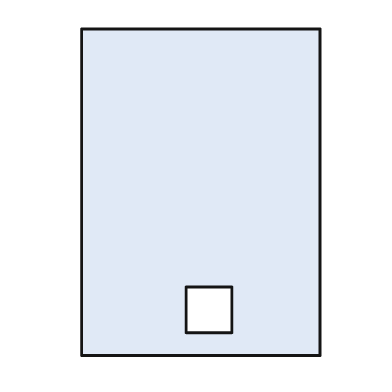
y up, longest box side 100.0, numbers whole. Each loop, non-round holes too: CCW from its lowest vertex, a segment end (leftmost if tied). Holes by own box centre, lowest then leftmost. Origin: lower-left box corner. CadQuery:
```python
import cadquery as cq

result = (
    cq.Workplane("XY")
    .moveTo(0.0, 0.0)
    .lineTo(73.0, 0.0)
    .lineTo(73.0, 100.0)
    .lineTo(0.0, 100.0)
    .close()
    .moveTo(32.0, 7.0)
    .lineTo(46.0, 7.0)
    .lineTo(46.0, 21.0)
    .lineTo(32.0, 21.0)
    .close()
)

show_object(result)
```